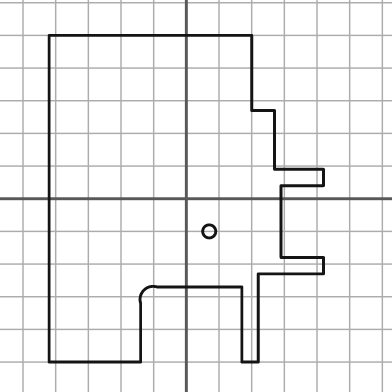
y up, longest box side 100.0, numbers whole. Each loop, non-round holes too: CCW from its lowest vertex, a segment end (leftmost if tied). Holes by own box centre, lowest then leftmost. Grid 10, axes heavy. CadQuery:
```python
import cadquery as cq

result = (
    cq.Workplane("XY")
    .moveTo(-42.0, -50.0)
    .lineTo(-14.0, -50.0)
    .lineTo(-14.0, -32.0)
    .threePointArc((-13.0, -28.0), (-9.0, -27.0))
    .lineTo(17.0, -27.0)
    .lineTo(17.0, -50.0)
    .lineTo(22.0, -50.0)
    .lineTo(22.0, -23.0)
    .lineTo(42.0, -23.0)
    .lineTo(42.0, -18.0)
    .lineTo(29.0, -18.0)
    .lineTo(29.0, 4.0)
    .lineTo(42.0, 4.0)
    .lineTo(42.0, 9.0)
    .lineTo(27.0, 9.0)
    .lineTo(27.0, 27.0)
    .lineTo(20.0, 27.0)
    .lineTo(20.0, 50.0)
    .lineTo(-42.0, 50.0)
    .close()
    .moveTo(7.0, -10.0)
    .circle(2.0)
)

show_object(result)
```